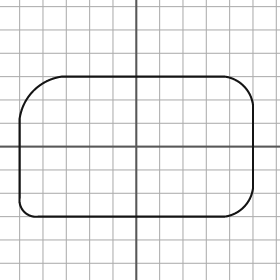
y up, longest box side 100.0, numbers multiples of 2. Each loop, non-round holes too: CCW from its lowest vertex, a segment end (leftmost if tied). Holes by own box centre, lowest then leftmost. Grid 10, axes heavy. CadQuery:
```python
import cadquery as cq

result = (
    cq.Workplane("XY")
    .moveTo(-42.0, -30.0)
    .lineTo(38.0, -30.0)
    .threePointArc((46.0, -26.0), (50.0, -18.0))
    .lineTo(50.0, 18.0)
    .threePointArc((46.0, 26.0), (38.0, 30.0))
    .lineTo(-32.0, 30.0)
    .threePointArc((-44.0, 24.0), (-50.0, 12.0))
    .lineTo(-50.0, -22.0)
    .threePointArc((-48.0, -28.0), (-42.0, -30.0))
    .close()
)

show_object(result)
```